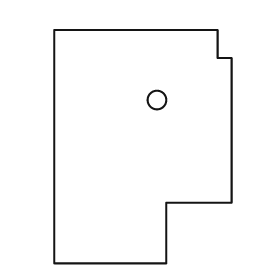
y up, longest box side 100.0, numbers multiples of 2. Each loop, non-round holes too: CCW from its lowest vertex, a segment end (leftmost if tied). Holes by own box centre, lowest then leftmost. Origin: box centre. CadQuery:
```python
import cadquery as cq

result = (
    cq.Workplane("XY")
    .moveTo(-38.0, -50.0)
    .lineTo(10.0, -50.0)
    .lineTo(10.0, -24.0)
    .lineTo(38.0, -24.0)
    .lineTo(38.0, 38.0)
    .lineTo(32.0, 38.0)
    .lineTo(32.0, 50.0)
    .lineTo(-38.0, 50.0)
    .close()
    .moveTo(6.0, 20.0)
    .circle(4.0)
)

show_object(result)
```